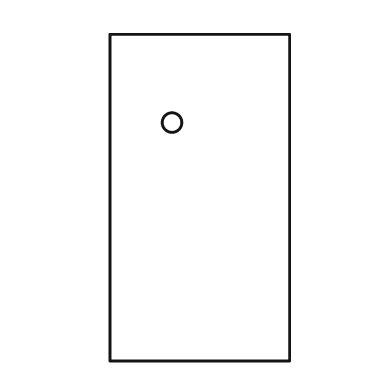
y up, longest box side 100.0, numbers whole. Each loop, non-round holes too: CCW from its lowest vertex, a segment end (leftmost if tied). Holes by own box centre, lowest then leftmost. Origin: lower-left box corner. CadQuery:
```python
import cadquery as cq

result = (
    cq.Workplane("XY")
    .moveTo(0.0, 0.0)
    .lineTo(55.0, 0.0)
    .lineTo(55.0, 100.0)
    .lineTo(0.0, 100.0)
    .close()
    .moveTo(19.0, 73.0)
    .circle(3.0)
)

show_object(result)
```